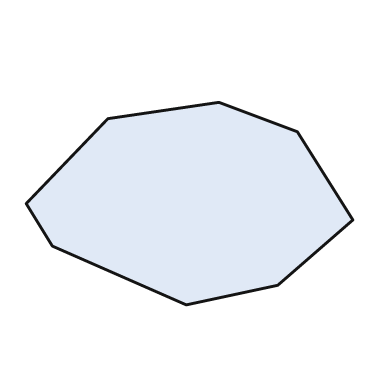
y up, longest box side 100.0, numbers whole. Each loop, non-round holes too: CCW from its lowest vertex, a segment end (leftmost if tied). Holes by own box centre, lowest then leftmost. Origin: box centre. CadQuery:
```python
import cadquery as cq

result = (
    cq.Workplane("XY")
    .moveTo(-1.0, -31.0)
    .lineTo(27.0, -25.0)
    .lineTo(50.0, -5.0)
    .lineTo(33.0, 22.0)
    .lineTo(9.0, 31.0)
    .lineTo(-25.0, 26.0)
    .lineTo(-50.0, 0.0)
    .lineTo(-42.0, -13.0)
    .close()
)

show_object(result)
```